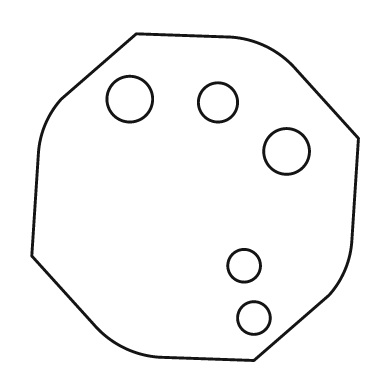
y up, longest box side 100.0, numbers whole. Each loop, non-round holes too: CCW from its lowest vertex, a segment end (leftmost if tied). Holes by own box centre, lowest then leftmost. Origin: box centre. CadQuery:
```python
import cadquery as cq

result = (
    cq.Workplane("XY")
    .moveTo(18.0, -50.0)
    .lineTo(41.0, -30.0)
    .threePointArc((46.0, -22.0), (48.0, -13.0))
    .lineTo(50.0, 18.0)
    .lineTo(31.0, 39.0)
    .threePointArc((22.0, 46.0), (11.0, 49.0))
    .lineTo(-18.0, 50.0)
    .lineTo(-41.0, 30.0)
    .threePointArc((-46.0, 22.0), (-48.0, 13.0))
    .lineTo(-50.0, -18.0)
    .lineTo(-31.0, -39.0)
    .threePointArc((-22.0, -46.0), (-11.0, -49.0))
    .close()
    .moveTo(18.0, -37.0)
    .circle(5.0)
    .moveTo(15.0, -21.0)
    .circle(5.0)
    .moveTo(28.0, 14.0)
    .circle(7.0)
    .moveTo(7.0, 29.0)
    .circle(6.0)
    .moveTo(-20.0, 30.0)
    .circle(7.0)
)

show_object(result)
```